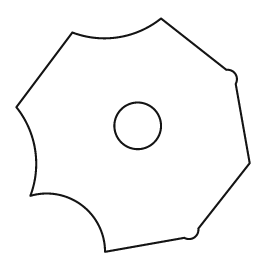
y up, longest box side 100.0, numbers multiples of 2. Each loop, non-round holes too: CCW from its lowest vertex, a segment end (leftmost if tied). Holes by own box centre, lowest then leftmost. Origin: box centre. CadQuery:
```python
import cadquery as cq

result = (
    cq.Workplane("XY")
    .moveTo(-12.0, -50.0)
    .lineTo(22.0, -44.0)
    .threePointArc((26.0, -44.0), (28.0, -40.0))
    .lineTo(50.0, -12.0)
    .lineTo(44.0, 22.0)
    .threePointArc((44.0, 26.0), (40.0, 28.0))
    .lineTo(12.0, 50.0)
    .threePointArc((-6.0, 42.0), (-26.0, 44.0))
    .lineTo(-50.0, 12.0)
    .threePointArc((-42.0, -6.0), (-44.0, -26.0))
    .threePointArc((-22.0, -30.0), (-12.0, -50.0))
    .close()
    .moveTo(2.0, 4.0)
    .circle(10.0)
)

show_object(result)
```